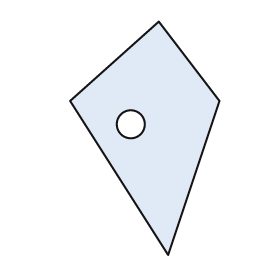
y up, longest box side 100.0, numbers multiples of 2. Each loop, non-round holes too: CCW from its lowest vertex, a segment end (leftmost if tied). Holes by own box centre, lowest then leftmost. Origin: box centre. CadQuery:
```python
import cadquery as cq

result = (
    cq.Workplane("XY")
    .moveTo(10.0, -50.0)
    .lineTo(32.0, 16.0)
    .lineTo(6.0, 50.0)
    .lineTo(-32.0, 16.0)
    .close()
    .moveTo(-6.0, 6.0)
    .circle(6.0)
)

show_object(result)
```